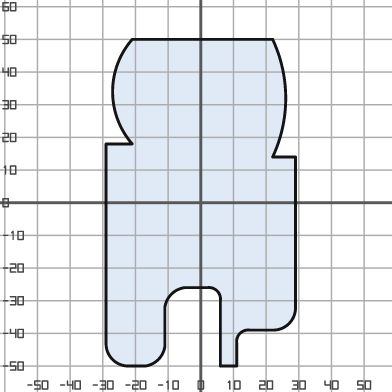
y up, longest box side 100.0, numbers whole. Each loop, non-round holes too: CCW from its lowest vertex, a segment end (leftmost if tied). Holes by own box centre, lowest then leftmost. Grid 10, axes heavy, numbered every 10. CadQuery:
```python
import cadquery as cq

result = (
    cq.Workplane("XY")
    .moveTo(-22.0, -50.0)
    .lineTo(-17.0, -50.0)
    .threePointArc((-13.0, -48.0), (-11.0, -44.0))
    .lineTo(-11.0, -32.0)
    .threePointArc((-9.0, -28.0), (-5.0, -26.0))
    .lineTo(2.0, -26.0)
    .threePointArc((5.0, -27.0), (6.0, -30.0))
    .lineTo(6.0, -50.0)
    .lineTo(11.0, -50.0)
    .lineTo(11.0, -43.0)
    .threePointArc((12.0, -40.0), (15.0, -39.0))
    .lineTo(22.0, -39.0)
    .threePointArc((27.0, -37.0), (29.0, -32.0))
    .lineTo(29.0, 14.0)
    .lineTo(22.0, 14.0)
    .threePointArc((26.0, 32.0), (22.0, 50.0))
    .lineTo(-21.0, 50.0)
    .threePointArc((-27.0, 34.0), (-21.0, 18.0))
    .lineTo(-29.0, 18.0)
    .lineTo(-29.0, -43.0)
    .threePointArc((-27.0, -48.0), (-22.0, -50.0))
    .close()
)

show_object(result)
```